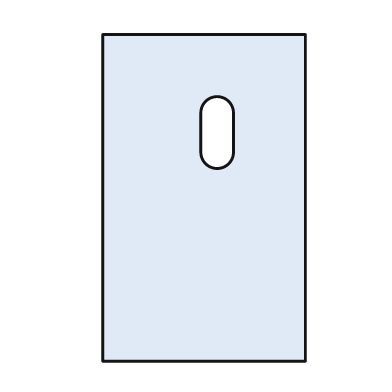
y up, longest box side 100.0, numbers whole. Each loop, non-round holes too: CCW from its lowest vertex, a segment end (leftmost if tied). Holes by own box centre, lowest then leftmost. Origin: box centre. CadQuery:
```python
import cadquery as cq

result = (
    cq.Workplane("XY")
    .moveTo(-31.0, -50.0)
    .lineTo(31.0, -50.0)
    .lineTo(31.0, 50.0)
    .lineTo(-31.0, 50.0)
    .close()
    .moveTo(-1.0, 14.0)
    .threePointArc((4.0, 9.0), (9.0, 14.0))
    .lineTo(9.0, 26.0)
    .threePointArc((4.0, 31.0), (-1.0, 26.0))
    .close()
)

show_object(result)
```